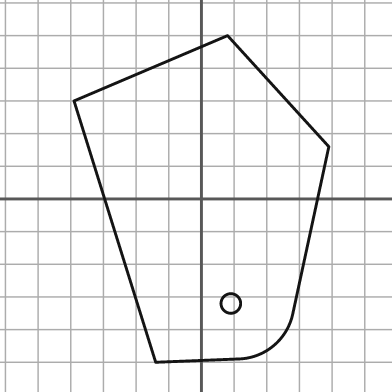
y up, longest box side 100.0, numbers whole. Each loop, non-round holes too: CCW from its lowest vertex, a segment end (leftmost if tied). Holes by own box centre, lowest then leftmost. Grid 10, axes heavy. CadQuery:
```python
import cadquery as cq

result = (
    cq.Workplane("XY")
    .moveTo(-14.0, -50.0)
    .lineTo(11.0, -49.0)
    .threePointArc((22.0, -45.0), (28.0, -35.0))
    .lineTo(39.0, 16.0)
    .lineTo(8.0, 50.0)
    .lineTo(-39.0, 30.0)
    .close()
    .moveTo(9.0, -32.0)
    .circle(3.0)
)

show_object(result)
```